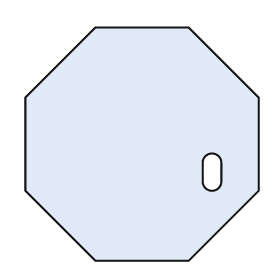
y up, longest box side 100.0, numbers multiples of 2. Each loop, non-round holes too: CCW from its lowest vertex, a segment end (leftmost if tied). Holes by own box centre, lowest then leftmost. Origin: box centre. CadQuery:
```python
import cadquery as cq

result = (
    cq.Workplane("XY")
    .moveTo(-20.0, -50.0)
    .lineTo(20.0, -50.0)
    .lineTo(50.0, -20.0)
    .lineTo(50.0, 20.0)
    .lineTo(20.0, 50.0)
    .lineTo(-20.0, 50.0)
    .lineTo(-50.0, 20.0)
    .lineTo(-50.0, -20.0)
    .close()
    .moveTo(26.0, -16.0)
    .threePointArc((30.0, -20.0), (34.0, -16.0))
    .lineTo(34.0, -8.0)
    .threePointArc((30.0, -4.0), (26.0, -8.0))
    .close()
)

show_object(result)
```